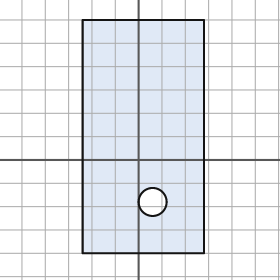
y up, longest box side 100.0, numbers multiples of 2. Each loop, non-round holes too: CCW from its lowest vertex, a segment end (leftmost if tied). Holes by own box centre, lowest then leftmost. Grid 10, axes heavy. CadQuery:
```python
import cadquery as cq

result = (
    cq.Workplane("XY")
    .moveTo(-24.0, -40.0)
    .lineTo(28.0, -40.0)
    .lineTo(28.0, 60.0)
    .lineTo(-24.0, 60.0)
    .close()
    .moveTo(6.0, -18.0)
    .circle(6.0)
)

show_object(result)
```